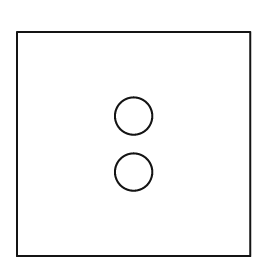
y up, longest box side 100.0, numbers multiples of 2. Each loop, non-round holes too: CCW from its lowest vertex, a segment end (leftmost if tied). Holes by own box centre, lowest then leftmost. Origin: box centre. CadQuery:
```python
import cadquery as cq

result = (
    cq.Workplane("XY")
    .moveTo(-50.0, -48.0)
    .lineTo(50.0, -48.0)
    .lineTo(50.0, 48.0)
    .lineTo(-50.0, 48.0)
    .close()
    .moveTo(0.0, -12.0)
    .circle(8.0)
    .moveTo(0.0, 12.0)
    .circle(8.0)
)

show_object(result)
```